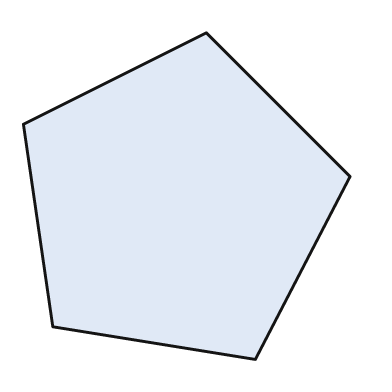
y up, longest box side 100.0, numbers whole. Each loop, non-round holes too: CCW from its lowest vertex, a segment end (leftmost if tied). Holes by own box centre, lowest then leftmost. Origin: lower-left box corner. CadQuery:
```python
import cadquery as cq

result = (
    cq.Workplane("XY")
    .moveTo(71.0, 0.0)
    .lineTo(100.0, 56.0)
    .lineTo(56.0, 100.0)
    .lineTo(0.0, 72.0)
    .lineTo(9.0, 10.0)
    .close()
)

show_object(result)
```